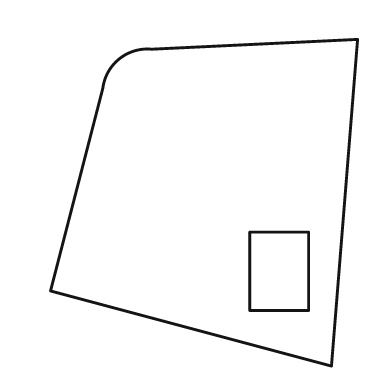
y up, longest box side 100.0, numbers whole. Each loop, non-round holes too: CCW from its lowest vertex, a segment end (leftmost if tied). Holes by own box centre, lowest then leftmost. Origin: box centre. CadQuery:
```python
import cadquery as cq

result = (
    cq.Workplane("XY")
    .moveTo(39.0, -50.0)
    .lineTo(47.0, 50.0)
    .lineTo(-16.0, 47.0)
    .threePointArc((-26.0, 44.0), (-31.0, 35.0))
    .lineTo(-47.0, -27.0)
    .close()
    .moveTo(14.0, -33.0)
    .lineTo(32.0, -33.0)
    .lineTo(32.0, -9.0)
    .lineTo(14.0, -9.0)
    .close()
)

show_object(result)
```